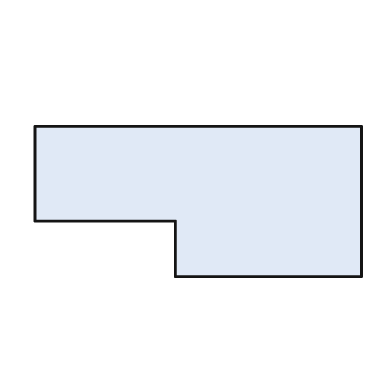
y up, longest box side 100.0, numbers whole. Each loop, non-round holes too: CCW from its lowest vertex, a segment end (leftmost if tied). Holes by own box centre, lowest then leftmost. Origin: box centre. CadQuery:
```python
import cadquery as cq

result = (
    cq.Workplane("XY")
    .moveTo(-7.0, -23.0)
    .lineTo(50.0, -23.0)
    .lineTo(50.0, 23.0)
    .lineTo(-50.0, 23.0)
    .lineTo(-50.0, -6.0)
    .lineTo(-7.0, -6.0)
    .close()
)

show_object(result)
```